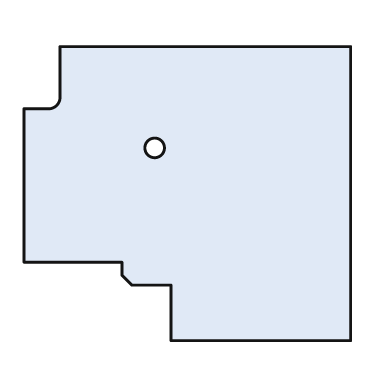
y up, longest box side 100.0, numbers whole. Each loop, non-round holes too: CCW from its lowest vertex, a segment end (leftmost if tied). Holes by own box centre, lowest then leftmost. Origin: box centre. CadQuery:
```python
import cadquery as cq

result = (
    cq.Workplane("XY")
    .moveTo(-5.0, -45.0)
    .lineTo(50.0, -45.0)
    .lineTo(50.0, 45.0)
    .lineTo(-39.0, 45.0)
    .lineTo(-39.0, 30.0)
    .threePointArc((-40.0, 27.0), (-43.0, 26.0))
    .lineTo(-50.0, 26.0)
    .lineTo(-50.0, -21.0)
    .lineTo(-20.0, -21.0)
    .lineTo(-20.0, -25.0)
    .lineTo(-17.0, -28.0)
    .lineTo(-5.0, -28.0)
    .close()
    .moveTo(-10.0, 14.0)
    .circle(3.0)
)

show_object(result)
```